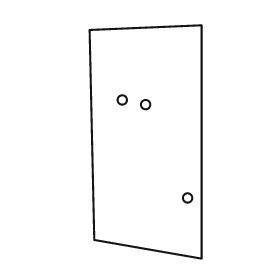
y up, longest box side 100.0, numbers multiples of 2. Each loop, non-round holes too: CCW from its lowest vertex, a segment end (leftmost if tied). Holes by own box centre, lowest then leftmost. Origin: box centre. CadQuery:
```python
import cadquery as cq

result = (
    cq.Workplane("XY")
    .moveTo(24.0, -50.0)
    .lineTo(24.0, 50.0)
    .lineTo(-24.0, 48.0)
    .lineTo(-22.0, -42.0)
    .close()
    .moveTo(18.0, -24.0)
    .circle(2.0)
    .moveTo(0.0, 16.0)
    .circle(2.0)
    .moveTo(-10.0, 18.0)
    .circle(2.0)
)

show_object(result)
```